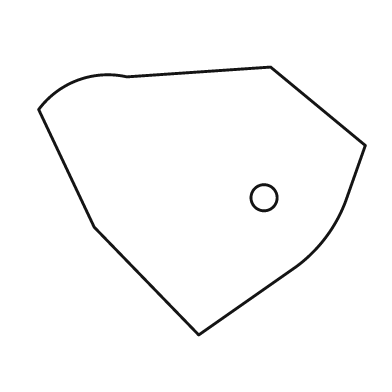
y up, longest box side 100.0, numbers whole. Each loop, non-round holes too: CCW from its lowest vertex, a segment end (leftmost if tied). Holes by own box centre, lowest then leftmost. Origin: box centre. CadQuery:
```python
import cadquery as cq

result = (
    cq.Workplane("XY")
    .moveTo(-1.0, -41.0)
    .lineTo(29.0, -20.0)
    .threePointArc((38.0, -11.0), (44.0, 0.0))
    .lineTo(50.0, 17.0)
    .lineTo(21.0, 41.0)
    .lineTo(-23.0, 38.0)
    .threePointArc((-38.0, 37.0), (-50.0, 28.0))
    .lineTo(-33.0, -8.0)
    .close()
    .moveTo(19.0, 1.0)
    .circle(4.0)
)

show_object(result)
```